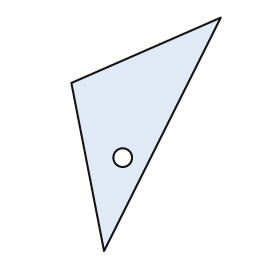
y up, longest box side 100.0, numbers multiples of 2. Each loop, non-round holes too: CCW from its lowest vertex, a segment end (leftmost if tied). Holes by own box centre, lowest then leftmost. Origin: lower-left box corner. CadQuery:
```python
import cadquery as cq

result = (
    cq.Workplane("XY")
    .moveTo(14.0, 0.0)
    .lineTo(64.0, 100.0)
    .lineTo(0.0, 72.0)
    .close()
    .moveTo(22.0, 40.0)
    .circle(4.0)
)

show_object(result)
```